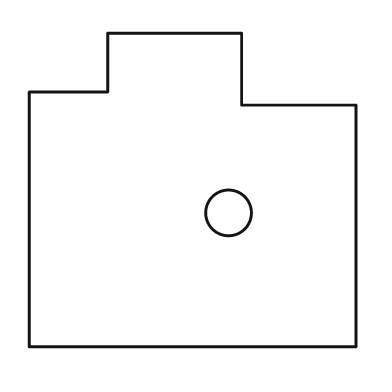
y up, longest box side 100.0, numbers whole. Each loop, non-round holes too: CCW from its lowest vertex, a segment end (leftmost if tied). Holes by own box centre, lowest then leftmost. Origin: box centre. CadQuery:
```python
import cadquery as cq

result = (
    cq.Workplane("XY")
    .moveTo(-50.0, -48.0)
    .lineTo(50.0, -48.0)
    .lineTo(50.0, 26.0)
    .lineTo(15.0, 26.0)
    .lineTo(15.0, 48.0)
    .lineTo(-26.0, 48.0)
    .lineTo(-26.0, 30.0)
    .lineTo(-50.0, 30.0)
    .close()
    .moveTo(11.0, -7.0)
    .circle(7.0)
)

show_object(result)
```